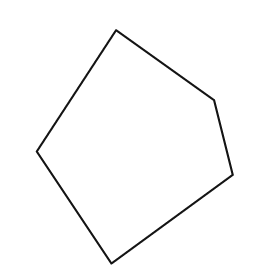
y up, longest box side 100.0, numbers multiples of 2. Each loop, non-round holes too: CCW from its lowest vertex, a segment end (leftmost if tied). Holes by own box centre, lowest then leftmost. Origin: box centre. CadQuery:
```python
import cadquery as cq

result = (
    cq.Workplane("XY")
    .moveTo(-10.0, -50.0)
    .lineTo(42.0, -12.0)
    .lineTo(34.0, 20.0)
    .lineTo(-8.0, 50.0)
    .lineTo(-42.0, -2.0)
    .close()
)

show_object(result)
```